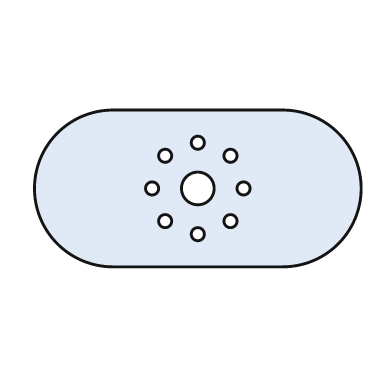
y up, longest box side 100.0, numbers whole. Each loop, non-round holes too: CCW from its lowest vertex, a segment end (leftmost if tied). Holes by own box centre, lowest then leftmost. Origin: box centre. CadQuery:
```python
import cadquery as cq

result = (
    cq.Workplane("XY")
    .moveTo(-26.0, -24.0)
    .lineTo(26.0, -24.0)
    .threePointArc((50.0, 0.0), (26.0, 24.0))
    .lineTo(-26.0, 24.0)
    .threePointArc((-50.0, 0.0), (-26.0, -24.0))
    .close()
    .moveTo(0.0, -14.0)
    .circle(2.0)
    .moveTo(-10.0, -10.0)
    .circle(2.0)
    .moveTo(10.0, -10.0)
    .circle(2.0)
    .moveTo(-14.0, 0.0)
    .circle(2.0)
    .moveTo(0.0, 0.0)
    .circle(5.0)
    .moveTo(14.0, 0.0)
    .circle(2.0)
    .moveTo(-10.0, 10.0)
    .circle(2.0)
    .moveTo(10.0, 10.0)
    .circle(2.0)
    .moveTo(0.0, 14.0)
    .circle(2.0)
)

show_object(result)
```